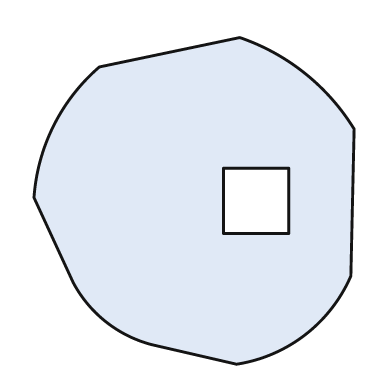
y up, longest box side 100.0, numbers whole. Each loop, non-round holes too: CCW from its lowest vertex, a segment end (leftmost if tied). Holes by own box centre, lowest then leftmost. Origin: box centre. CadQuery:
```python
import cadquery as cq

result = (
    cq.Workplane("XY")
    .moveTo(13.0, -50.0)
    .threePointArc((34.0, -41.0), (48.0, -23.0))
    .lineTo(49.0, 22.0)
    .threePointArc((34.0, 39.0), (14.0, 50.0))
    .lineTo(-29.0, 41.0)
    .threePointArc((-43.0, 23.0), (-49.0, 1.0))
    .lineTo(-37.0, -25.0)
    .threePointArc((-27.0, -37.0), (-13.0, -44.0))
    .close()
    .moveTo(9.0, -10.0)
    .lineTo(29.0, -10.0)
    .lineTo(29.0, 10.0)
    .lineTo(9.0, 10.0)
    .close()
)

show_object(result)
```